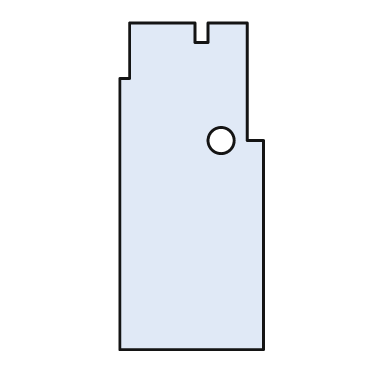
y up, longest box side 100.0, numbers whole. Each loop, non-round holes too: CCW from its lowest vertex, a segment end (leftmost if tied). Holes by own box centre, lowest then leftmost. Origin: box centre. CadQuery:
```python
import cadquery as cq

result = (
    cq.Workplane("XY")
    .moveTo(-22.0, -50.0)
    .lineTo(22.0, -50.0)
    .lineTo(22.0, 14.0)
    .lineTo(17.0, 14.0)
    .lineTo(17.0, 50.0)
    .lineTo(5.0, 50.0)
    .lineTo(5.0, 44.0)
    .lineTo(1.0, 44.0)
    .lineTo(1.0, 50.0)
    .lineTo(-19.0, 50.0)
    .lineTo(-19.0, 33.0)
    .lineTo(-22.0, 33.0)
    .close()
    .moveTo(9.0, 14.0)
    .circle(4.0)
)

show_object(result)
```